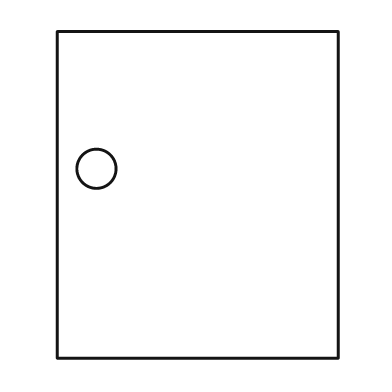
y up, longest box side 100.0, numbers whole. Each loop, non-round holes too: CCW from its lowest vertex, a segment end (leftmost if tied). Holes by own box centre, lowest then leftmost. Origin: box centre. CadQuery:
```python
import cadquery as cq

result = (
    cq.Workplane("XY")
    .moveTo(-43.0, -50.0)
    .lineTo(43.0, -50.0)
    .lineTo(43.0, 50.0)
    .lineTo(-43.0, 50.0)
    .close()
    .moveTo(-31.0, 8.0)
    .circle(6.0)
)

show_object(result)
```